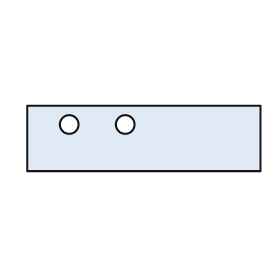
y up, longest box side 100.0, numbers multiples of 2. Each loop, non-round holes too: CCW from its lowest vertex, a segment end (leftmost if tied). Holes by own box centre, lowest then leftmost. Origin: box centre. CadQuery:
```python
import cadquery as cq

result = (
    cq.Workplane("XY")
    .moveTo(-50.0, -14.0)
    .lineTo(50.0, -14.0)
    .lineTo(50.0, 14.0)
    .lineTo(-50.0, 14.0)
    .close()
    .moveTo(-32.0, 6.0)
    .circle(4.0)
    .moveTo(-8.0, 6.0)
    .circle(4.0)
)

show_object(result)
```